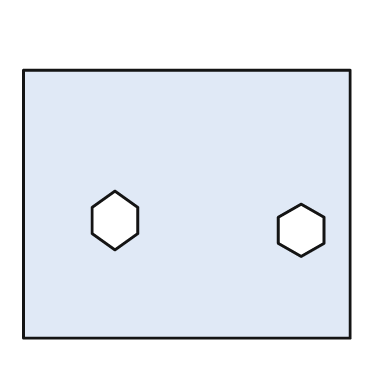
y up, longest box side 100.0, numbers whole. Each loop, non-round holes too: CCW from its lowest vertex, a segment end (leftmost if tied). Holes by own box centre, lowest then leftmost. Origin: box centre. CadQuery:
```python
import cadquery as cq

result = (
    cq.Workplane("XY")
    .moveTo(-50.0, -41.0)
    .lineTo(50.0, -41.0)
    .lineTo(50.0, 41.0)
    .lineTo(-50.0, 41.0)
    .close()
    .moveTo(35.0, -16.0)
    .lineTo(42.0, -12.0)
    .lineTo(42.0, -4.0)
    .lineTo(35.0, 0.0)
    .lineTo(28.0, -4.0)
    .lineTo(28.0, -12.0)
    .close()
    .moveTo(-22.0, -14.0)
    .lineTo(-15.0, -9.0)
    .lineTo(-15.0, -1.0)
    .lineTo(-22.0, 4.0)
    .lineTo(-29.0, -1.0)
    .lineTo(-29.0, -9.0)
    .close()
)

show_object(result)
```